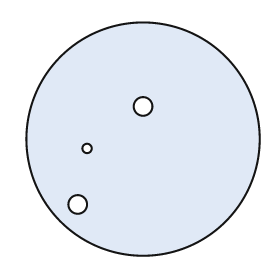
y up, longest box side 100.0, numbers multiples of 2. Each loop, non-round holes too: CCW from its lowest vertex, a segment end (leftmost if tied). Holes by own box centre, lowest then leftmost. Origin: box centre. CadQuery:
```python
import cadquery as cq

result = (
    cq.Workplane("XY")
    .moveTo(0.0, 0.0)
    .circle(50.0)
    .moveTo(-28.0, -28.0)
    .circle(4.0)
    .moveTo(-24.0, -4.0)
    .circle(2.0)
    .moveTo(0.0, 14.0)
    .circle(4.0)
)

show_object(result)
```